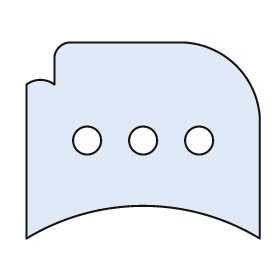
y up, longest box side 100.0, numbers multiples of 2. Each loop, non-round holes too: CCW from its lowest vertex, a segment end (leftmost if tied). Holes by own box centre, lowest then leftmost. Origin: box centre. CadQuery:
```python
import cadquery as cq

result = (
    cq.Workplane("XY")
    .moveTo(-50.0, -42.0)
    .threePointArc((0.0, -28.0), (50.0, -42.0))
    .lineTo(50.0, 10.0)
    .threePointArc((40.0, 32.0), (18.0, 42.0))
    .lineTo(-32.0, 42.0)
    .threePointArc((-36.0, 40.0), (-38.0, 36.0))
    .lineTo(-38.0, 24.0)
    .threePointArc((-44.0, 26.0), (-50.0, 24.0))
    .close()
    .moveTo(-24.0, 0.0)
    .circle(6.0)
    .moveTo(0.0, 0.0)
    .circle(6.0)
    .moveTo(24.0, 0.0)
    .circle(6.0)
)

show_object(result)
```